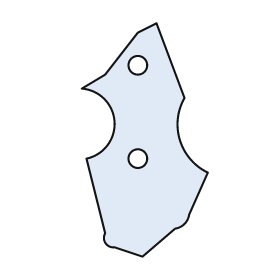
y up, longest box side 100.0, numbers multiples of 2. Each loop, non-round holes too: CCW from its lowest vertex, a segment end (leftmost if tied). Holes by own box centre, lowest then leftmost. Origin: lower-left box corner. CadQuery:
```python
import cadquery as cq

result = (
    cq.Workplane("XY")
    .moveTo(26.0, 0.0)
    .lineTo(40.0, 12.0)
    .threePointArc((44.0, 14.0), (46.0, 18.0))
    .lineTo(54.0, 36.0)
    .threePointArc((42.0, 50.0), (44.0, 68.0))
    .lineTo(32.0, 100.0)
    .lineTo(24.0, 96.0)
    .lineTo(10.0, 78.0)
    .lineTo(0.0, 72.0)
    .threePointArc((14.0, 58.0), (2.0, 42.0))
    .lineTo(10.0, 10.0)
    .threePointArc((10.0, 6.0), (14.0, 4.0))
    .close()
    .moveTo(24.0, 42.0)
    .circle(4.0)
    .moveTo(24.0, 82.0)
    .circle(4.0)
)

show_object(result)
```